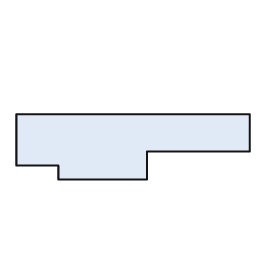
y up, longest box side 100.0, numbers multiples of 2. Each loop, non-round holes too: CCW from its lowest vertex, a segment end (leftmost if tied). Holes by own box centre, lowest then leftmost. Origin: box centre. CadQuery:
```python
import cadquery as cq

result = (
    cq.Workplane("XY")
    .moveTo(-32.0, -14.0)
    .lineTo(6.0, -14.0)
    .lineTo(6.0, -2.0)
    .lineTo(50.0, -2.0)
    .lineTo(50.0, 14.0)
    .lineTo(-50.0, 14.0)
    .lineTo(-50.0, -8.0)
    .lineTo(-32.0, -8.0)
    .close()
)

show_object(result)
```